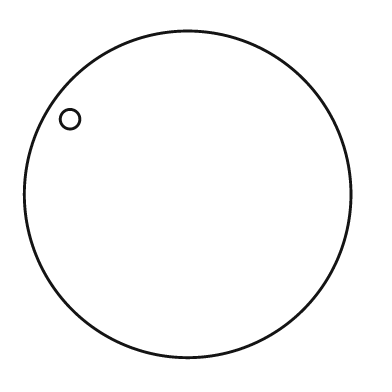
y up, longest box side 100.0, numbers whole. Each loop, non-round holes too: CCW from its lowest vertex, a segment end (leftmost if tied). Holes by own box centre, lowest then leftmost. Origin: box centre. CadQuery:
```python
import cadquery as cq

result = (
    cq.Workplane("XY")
    .moveTo(0.0, 0.0)
    .circle(50.0)
    .moveTo(-36.0, 23.0)
    .circle(3.0)
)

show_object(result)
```